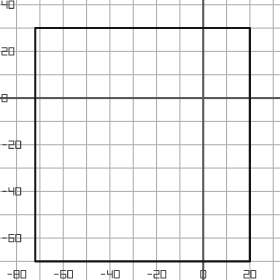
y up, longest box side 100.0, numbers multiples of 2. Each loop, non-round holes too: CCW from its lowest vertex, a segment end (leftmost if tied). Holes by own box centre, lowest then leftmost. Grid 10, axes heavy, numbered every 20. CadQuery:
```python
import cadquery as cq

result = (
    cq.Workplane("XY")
    .moveTo(-72.0, -70.0)
    .lineTo(20.0, -70.0)
    .lineTo(20.0, 30.0)
    .lineTo(-72.0, 30.0)
    .close()
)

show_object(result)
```